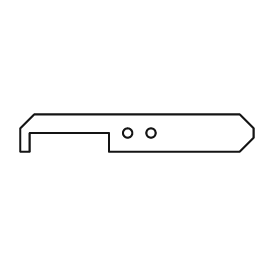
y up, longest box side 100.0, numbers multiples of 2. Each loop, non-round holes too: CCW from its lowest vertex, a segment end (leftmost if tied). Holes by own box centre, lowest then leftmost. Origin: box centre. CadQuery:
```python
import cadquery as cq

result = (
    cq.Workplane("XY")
    .moveTo(-50.0, -8.0)
    .lineTo(-46.0, -8.0)
    .lineTo(-46.0, 0.0)
    .lineTo(-12.0, 0.0)
    .lineTo(-12.0, -8.0)
    .lineTo(44.0, -8.0)
    .lineTo(50.0, -2.0)
    .lineTo(50.0, 2.0)
    .lineTo(44.0, 8.0)
    .lineTo(-44.0, 8.0)
    .lineTo(-50.0, 2.0)
    .close()
    .moveTo(-4.0, 0.0)
    .circle(2.0)
    .moveTo(6.0, 0.0)
    .circle(2.0)
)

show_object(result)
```